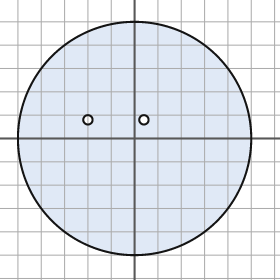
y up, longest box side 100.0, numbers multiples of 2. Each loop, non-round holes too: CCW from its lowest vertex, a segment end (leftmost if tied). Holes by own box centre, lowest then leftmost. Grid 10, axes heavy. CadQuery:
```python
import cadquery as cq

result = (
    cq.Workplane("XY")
    .moveTo(0.0, 0.0)
    .circle(50.0)
    .moveTo(-20.0, 8.0)
    .circle(2.0)
    .moveTo(4.0, 8.0)
    .circle(2.0)
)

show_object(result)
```